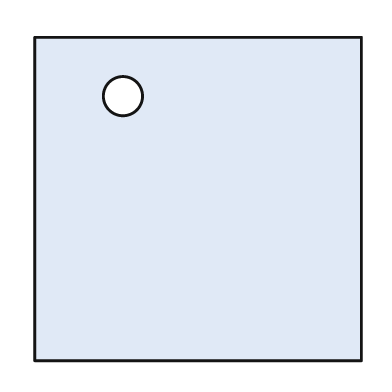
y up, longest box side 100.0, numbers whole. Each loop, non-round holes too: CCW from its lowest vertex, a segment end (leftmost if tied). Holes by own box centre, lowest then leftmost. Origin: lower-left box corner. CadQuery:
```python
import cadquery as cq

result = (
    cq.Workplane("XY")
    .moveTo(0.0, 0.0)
    .lineTo(100.0, 0.0)
    .lineTo(100.0, 99.0)
    .lineTo(0.0, 99.0)
    .close()
    .moveTo(27.0, 81.0)
    .circle(6.0)
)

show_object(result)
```